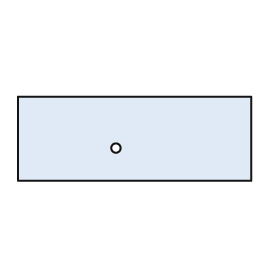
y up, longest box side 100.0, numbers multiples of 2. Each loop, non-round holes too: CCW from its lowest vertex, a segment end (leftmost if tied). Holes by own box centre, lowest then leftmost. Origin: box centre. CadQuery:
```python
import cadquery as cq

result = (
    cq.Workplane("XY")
    .moveTo(-50.0, -18.0)
    .lineTo(50.0, -18.0)
    .lineTo(50.0, 18.0)
    .lineTo(-50.0, 18.0)
    .close()
    .moveTo(-8.0, -4.0)
    .circle(2.0)
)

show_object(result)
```